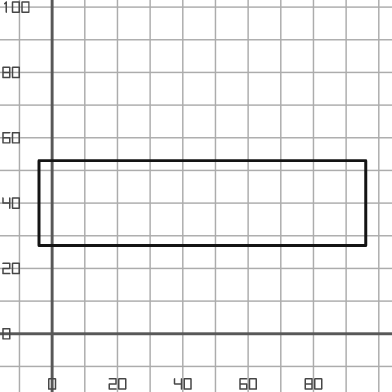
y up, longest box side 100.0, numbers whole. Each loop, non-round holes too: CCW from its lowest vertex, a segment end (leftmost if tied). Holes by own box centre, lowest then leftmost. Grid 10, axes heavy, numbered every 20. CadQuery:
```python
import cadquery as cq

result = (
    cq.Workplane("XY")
    .moveTo(-4.0, 27.0)
    .lineTo(96.0, 27.0)
    .lineTo(96.0, 53.0)
    .lineTo(-4.0, 53.0)
    .close()
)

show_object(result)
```